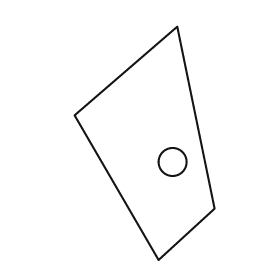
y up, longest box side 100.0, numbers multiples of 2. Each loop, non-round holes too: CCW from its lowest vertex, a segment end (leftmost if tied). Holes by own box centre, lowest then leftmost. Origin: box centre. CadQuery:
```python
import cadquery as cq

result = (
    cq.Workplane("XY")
    .moveTo(6.0, -50.0)
    .lineTo(30.0, -28.0)
    .lineTo(14.0, 50.0)
    .lineTo(-30.0, 12.0)
    .close()
    .moveTo(12.0, -8.0)
    .circle(6.0)
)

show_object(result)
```